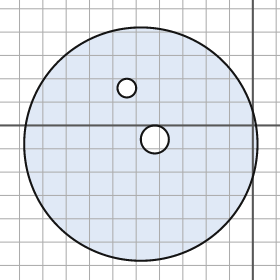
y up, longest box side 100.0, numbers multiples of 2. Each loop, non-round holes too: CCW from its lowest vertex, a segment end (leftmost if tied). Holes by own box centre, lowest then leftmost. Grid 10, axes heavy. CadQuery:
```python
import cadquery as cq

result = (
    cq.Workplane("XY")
    .moveTo(-48.0, -8.0)
    .circle(50.0)
    .moveTo(-42.0, -6.0)
    .circle(6.0)
    .moveTo(-54.0, 16.0)
    .circle(4.0)
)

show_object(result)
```